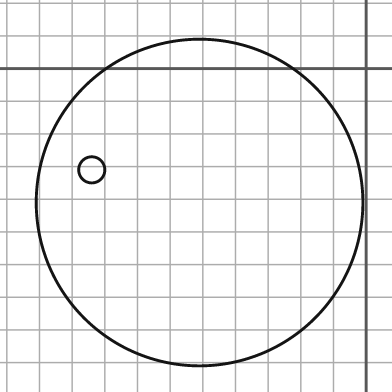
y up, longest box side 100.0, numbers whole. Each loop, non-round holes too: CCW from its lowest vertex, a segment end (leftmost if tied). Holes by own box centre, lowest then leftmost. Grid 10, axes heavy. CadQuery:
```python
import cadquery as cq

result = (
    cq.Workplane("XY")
    .moveTo(-51.0, -41.0)
    .circle(50.0)
    .moveTo(-84.0, -31.0)
    .circle(4.0)
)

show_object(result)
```